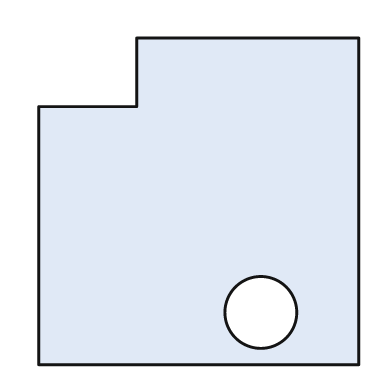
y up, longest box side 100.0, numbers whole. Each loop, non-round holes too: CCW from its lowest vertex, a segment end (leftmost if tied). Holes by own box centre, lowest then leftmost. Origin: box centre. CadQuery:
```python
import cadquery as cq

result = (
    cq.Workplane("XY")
    .moveTo(-49.0, -50.0)
    .lineTo(49.0, -50.0)
    .lineTo(49.0, 50.0)
    .lineTo(-19.0, 50.0)
    .lineTo(-19.0, 29.0)
    .lineTo(-49.0, 29.0)
    .close()
    .moveTo(19.0, -34.0)
    .circle(11.0)
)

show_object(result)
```